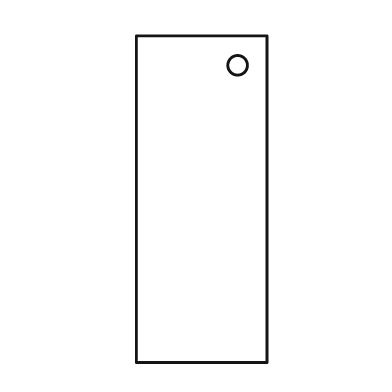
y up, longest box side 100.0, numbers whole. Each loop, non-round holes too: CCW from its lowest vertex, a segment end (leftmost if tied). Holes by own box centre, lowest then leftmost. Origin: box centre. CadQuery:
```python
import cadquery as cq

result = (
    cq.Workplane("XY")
    .moveTo(-20.0, -50.0)
    .lineTo(20.0, -50.0)
    .lineTo(20.0, 50.0)
    .lineTo(-20.0, 50.0)
    .close()
    .moveTo(11.0, 41.0)
    .circle(3.0)
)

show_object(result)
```